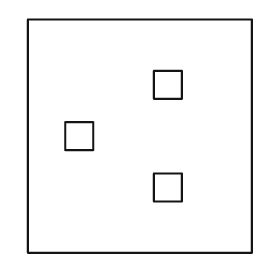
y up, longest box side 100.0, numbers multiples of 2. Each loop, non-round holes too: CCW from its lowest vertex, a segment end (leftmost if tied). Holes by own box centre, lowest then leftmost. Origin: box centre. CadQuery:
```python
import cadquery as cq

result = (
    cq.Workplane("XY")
    .moveTo(-48.0, -50.0)
    .lineTo(48.0, -50.0)
    .lineTo(48.0, 50.0)
    .lineTo(-48.0, 50.0)
    .close()
    .moveTo(6.0, -28.0)
    .lineTo(18.0, -28.0)
    .lineTo(18.0, -16.0)
    .lineTo(6.0, -16.0)
    .close()
    .moveTo(-32.0, -6.0)
    .lineTo(-20.0, -6.0)
    .lineTo(-20.0, 6.0)
    .lineTo(-32.0, 6.0)
    .close()
    .moveTo(6.0, 16.0)
    .lineTo(18.0, 16.0)
    .lineTo(18.0, 28.0)
    .lineTo(6.0, 28.0)
    .close()
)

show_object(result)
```